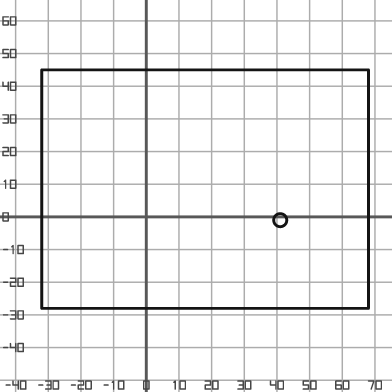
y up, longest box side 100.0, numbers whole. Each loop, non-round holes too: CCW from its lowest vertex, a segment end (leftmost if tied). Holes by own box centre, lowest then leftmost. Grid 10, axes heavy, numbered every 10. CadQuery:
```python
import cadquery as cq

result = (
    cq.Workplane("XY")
    .moveTo(-32.0, -28.0)
    .lineTo(68.0, -28.0)
    .lineTo(68.0, 45.0)
    .lineTo(-32.0, 45.0)
    .close()
    .moveTo(41.0, -1.0)
    .circle(2.0)
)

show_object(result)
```